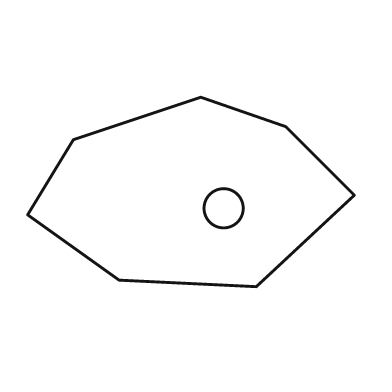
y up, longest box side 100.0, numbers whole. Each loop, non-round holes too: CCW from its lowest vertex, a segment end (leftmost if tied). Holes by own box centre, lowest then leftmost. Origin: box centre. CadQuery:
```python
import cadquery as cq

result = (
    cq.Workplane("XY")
    .moveTo(20.0, -29.0)
    .lineTo(50.0, -1.0)
    .lineTo(29.0, 20.0)
    .lineTo(3.0, 29.0)
    .lineTo(-36.0, 16.0)
    .lineTo(-50.0, -7.0)
    .lineTo(-22.0, -27.0)
    .close()
    .moveTo(10.0, -5.0)
    .circle(6.0)
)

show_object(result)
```